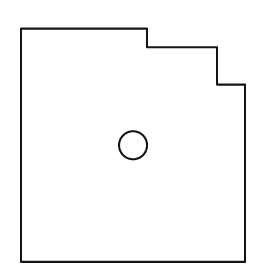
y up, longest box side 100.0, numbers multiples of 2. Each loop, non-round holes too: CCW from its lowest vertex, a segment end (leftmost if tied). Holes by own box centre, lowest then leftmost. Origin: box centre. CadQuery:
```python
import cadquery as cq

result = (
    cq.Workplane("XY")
    .moveTo(-48.0, -50.0)
    .lineTo(48.0, -50.0)
    .lineTo(48.0, 26.0)
    .lineTo(36.0, 26.0)
    .lineTo(36.0, 42.0)
    .lineTo(6.0, 42.0)
    .lineTo(6.0, 50.0)
    .lineTo(-48.0, 50.0)
    .close()
    .moveTo(0.0, 0.0)
    .circle(6.0)
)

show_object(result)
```